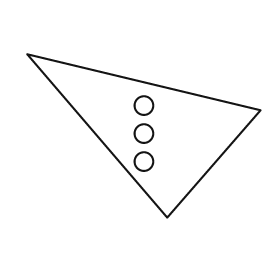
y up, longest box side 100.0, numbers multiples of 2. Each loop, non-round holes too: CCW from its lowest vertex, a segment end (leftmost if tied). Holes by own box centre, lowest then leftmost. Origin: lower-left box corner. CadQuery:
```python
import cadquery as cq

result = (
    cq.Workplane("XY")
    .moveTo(60.0, 0.0)
    .lineTo(100.0, 46.0)
    .lineTo(0.0, 70.0)
    .close()
    .moveTo(50.0, 24.0)
    .circle(4.0)
    .moveTo(50.0, 36.0)
    .circle(4.0)
    .moveTo(50.0, 48.0)
    .circle(4.0)
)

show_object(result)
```